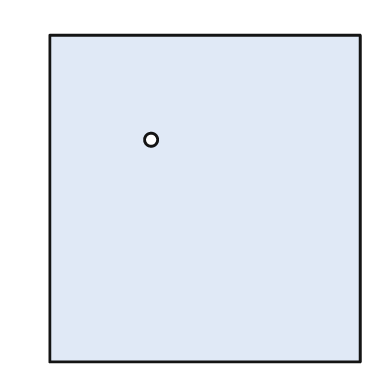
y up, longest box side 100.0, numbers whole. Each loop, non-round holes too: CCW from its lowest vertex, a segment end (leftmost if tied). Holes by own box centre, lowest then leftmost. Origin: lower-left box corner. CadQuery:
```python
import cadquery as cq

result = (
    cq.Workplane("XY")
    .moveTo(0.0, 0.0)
    .lineTo(95.0, 0.0)
    .lineTo(95.0, 100.0)
    .lineTo(0.0, 100.0)
    .close()
    .moveTo(31.0, 68.0)
    .circle(2.0)
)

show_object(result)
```